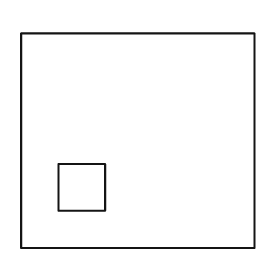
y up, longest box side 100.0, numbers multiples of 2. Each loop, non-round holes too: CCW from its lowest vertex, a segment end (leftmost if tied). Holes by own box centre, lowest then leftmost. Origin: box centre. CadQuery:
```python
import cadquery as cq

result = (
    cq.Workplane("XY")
    .moveTo(-50.0, -46.0)
    .lineTo(50.0, -46.0)
    .lineTo(50.0, 46.0)
    .lineTo(-50.0, 46.0)
    .close()
    .moveTo(-34.0, -30.0)
    .lineTo(-14.0, -30.0)
    .lineTo(-14.0, -10.0)
    .lineTo(-34.0, -10.0)
    .close()
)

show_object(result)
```